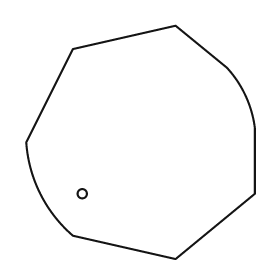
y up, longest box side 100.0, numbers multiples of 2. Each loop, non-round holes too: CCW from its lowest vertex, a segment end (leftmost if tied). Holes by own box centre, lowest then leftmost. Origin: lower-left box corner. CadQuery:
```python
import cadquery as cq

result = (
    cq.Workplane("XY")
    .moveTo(64.0, 0.0)
    .lineTo(98.0, 28.0)
    .lineTo(98.0, 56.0)
    .threePointArc((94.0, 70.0), (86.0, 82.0))
    .lineTo(64.0, 100.0)
    .lineTo(20.0, 90.0)
    .lineTo(0.0, 50.0)
    .threePointArc((6.0, 28.0), (20.0, 10.0))
    .close()
    .moveTo(24.0, 28.0)
    .circle(2.0)
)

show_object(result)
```